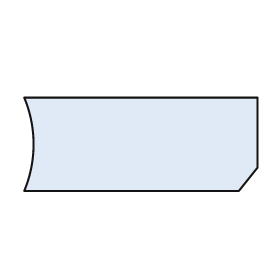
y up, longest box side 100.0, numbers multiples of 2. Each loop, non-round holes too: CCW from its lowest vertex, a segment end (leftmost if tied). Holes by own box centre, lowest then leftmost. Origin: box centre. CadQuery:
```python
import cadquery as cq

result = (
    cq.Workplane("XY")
    .moveTo(-50.0, -20.0)
    .lineTo(42.0, -20.0)
    .lineTo(50.0, -10.0)
    .lineTo(50.0, 20.0)
    .lineTo(-50.0, 20.0)
    .threePointArc((-46.0, 0.0), (-50.0, -20.0))
    .close()
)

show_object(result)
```